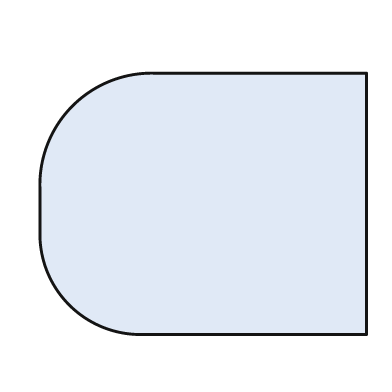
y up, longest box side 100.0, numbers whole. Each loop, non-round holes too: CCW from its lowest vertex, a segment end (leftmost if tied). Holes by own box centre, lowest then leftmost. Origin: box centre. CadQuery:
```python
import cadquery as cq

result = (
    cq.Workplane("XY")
    .moveTo(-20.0, -40.0)
    .lineTo(50.0, -40.0)
    .lineTo(50.0, 40.0)
    .lineTo(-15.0, 40.0)
    .threePointArc((-40.0, 30.0), (-50.0, 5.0))
    .lineTo(-50.0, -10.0)
    .threePointArc((-41.0, -31.0), (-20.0, -40.0))
    .close()
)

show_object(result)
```